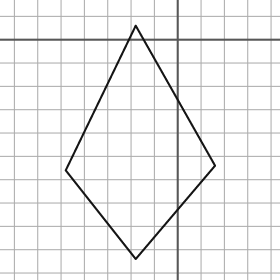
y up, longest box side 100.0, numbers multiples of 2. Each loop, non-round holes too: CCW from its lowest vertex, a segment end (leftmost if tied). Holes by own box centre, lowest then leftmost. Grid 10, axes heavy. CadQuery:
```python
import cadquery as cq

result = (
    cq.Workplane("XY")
    .moveTo(-18.0, -94.0)
    .lineTo(16.0, -54.0)
    .lineTo(-18.0, 6.0)
    .lineTo(-48.0, -56.0)
    .close()
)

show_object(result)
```